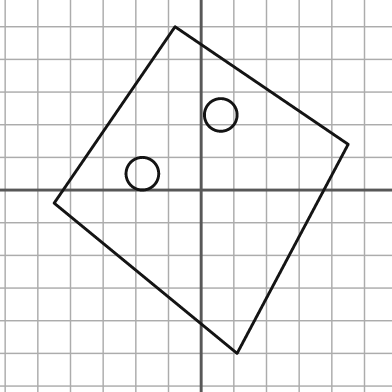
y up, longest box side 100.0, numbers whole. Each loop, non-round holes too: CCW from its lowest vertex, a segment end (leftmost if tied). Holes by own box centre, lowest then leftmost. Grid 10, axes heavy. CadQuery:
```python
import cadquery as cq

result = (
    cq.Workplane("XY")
    .moveTo(11.0, -50.0)
    .lineTo(45.0, 14.0)
    .lineTo(-8.0, 50.0)
    .lineTo(-45.0, -4.0)
    .close()
    .moveTo(-18.0, 5.0)
    .circle(5.0)
    .moveTo(6.0, 23.0)
    .circle(5.0)
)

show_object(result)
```